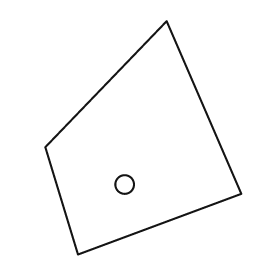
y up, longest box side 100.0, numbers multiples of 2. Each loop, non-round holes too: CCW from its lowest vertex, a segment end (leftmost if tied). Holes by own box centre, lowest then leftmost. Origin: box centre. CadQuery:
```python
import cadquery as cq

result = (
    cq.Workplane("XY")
    .moveTo(-28.0, -50.0)
    .lineTo(42.0, -24.0)
    .lineTo(10.0, 50.0)
    .lineTo(-42.0, -4.0)
    .close()
    .moveTo(-8.0, -20.0)
    .circle(4.0)
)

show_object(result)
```